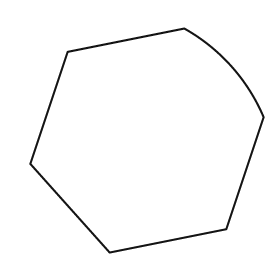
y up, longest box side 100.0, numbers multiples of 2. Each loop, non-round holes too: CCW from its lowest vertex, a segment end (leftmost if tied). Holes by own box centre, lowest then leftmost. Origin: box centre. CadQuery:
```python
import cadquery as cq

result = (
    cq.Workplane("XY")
    .moveTo(-16.0, -48.0)
    .lineTo(34.0, -38.0)
    .lineTo(50.0, 10.0)
    .threePointArc((36.0, 32.0), (16.0, 48.0))
    .lineTo(-34.0, 38.0)
    .lineTo(-50.0, -10.0)
    .close()
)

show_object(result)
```